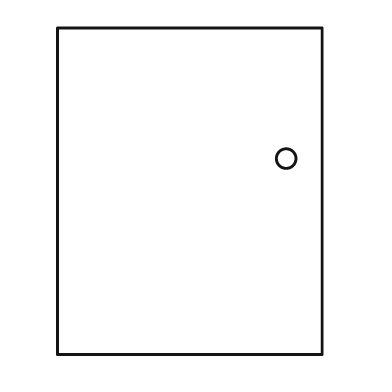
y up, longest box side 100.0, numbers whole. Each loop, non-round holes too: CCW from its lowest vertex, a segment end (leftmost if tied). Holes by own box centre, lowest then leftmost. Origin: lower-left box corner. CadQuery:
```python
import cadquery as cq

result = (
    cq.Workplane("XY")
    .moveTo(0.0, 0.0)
    .lineTo(81.0, 0.0)
    .lineTo(81.0, 100.0)
    .lineTo(0.0, 100.0)
    .close()
    .moveTo(70.0, 60.0)
    .circle(3.0)
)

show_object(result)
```